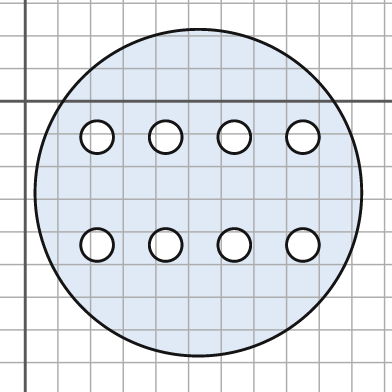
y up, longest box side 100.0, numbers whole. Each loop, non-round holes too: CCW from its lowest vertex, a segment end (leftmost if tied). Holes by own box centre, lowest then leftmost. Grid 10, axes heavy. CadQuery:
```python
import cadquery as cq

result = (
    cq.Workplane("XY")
    .moveTo(53.0, -28.0)
    .circle(50.0)
    .moveTo(22.0, -44.0)
    .circle(5.0)
    .moveTo(43.0, -44.0)
    .circle(5.0)
    .moveTo(64.0, -44.0)
    .circle(5.0)
    .moveTo(85.0, -44.0)
    .circle(5.0)
    .moveTo(22.0, -11.0)
    .circle(5.0)
    .moveTo(43.0, -11.0)
    .circle(5.0)
    .moveTo(64.0, -11.0)
    .circle(5.0)
    .moveTo(85.0, -11.0)
    .circle(5.0)
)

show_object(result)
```